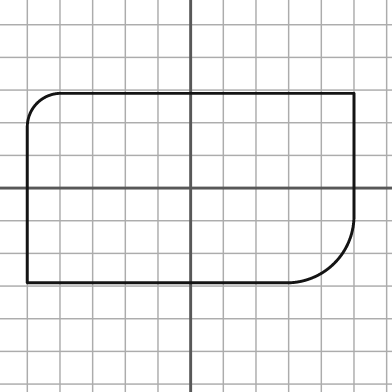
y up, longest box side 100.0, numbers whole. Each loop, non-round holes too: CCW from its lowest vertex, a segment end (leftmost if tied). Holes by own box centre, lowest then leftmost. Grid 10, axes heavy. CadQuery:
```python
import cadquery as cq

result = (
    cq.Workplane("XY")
    .moveTo(-50.0, -29.0)
    .lineTo(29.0, -29.0)
    .threePointArc((44.0, -23.0), (50.0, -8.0))
    .lineTo(50.0, 29.0)
    .lineTo(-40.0, 29.0)
    .threePointArc((-47.0, 26.0), (-50.0, 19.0))
    .close()
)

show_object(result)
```